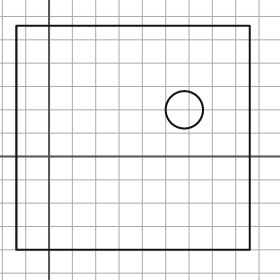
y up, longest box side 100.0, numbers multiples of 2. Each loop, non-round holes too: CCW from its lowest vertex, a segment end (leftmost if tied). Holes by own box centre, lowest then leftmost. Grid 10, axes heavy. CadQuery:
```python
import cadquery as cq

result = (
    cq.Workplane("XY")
    .moveTo(-14.0, -40.0)
    .lineTo(86.0, -40.0)
    .lineTo(86.0, 56.0)
    .lineTo(-14.0, 56.0)
    .close()
    .moveTo(58.0, 20.0)
    .circle(8.0)
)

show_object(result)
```